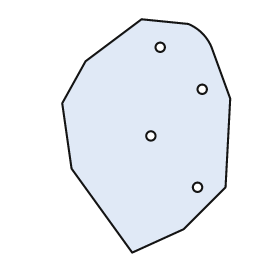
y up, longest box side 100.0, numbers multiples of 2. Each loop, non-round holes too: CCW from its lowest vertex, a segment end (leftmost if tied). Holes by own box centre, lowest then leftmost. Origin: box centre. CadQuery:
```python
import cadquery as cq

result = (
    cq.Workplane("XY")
    .moveTo(-6.0, -50.0)
    .lineTo(16.0, -40.0)
    .lineTo(34.0, -22.0)
    .lineTo(36.0, 16.0)
    .lineTo(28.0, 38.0)
    .threePointArc((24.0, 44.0), (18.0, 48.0))
    .lineTo(-2.0, 50.0)
    .lineTo(-26.0, 32.0)
    .lineTo(-36.0, 14.0)
    .lineTo(-32.0, -14.0)
    .close()
    .moveTo(22.0, -22.0)
    .circle(2.0)
    .moveTo(2.0, 0.0)
    .circle(2.0)
    .moveTo(24.0, 20.0)
    .circle(2.0)
    .moveTo(6.0, 38.0)
    .circle(2.0)
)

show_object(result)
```